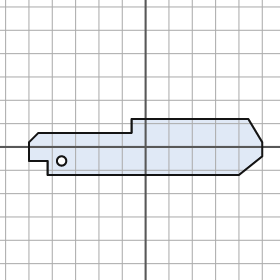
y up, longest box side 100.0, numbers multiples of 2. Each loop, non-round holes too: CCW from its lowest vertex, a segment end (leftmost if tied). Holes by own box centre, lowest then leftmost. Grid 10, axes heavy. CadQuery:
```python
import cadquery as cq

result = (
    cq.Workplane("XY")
    .moveTo(-42.0, -12.0)
    .lineTo(40.0, -12.0)
    .lineTo(50.0, -4.0)
    .lineTo(50.0, 2.0)
    .lineTo(44.0, 12.0)
    .lineTo(-6.0, 12.0)
    .lineTo(-6.0, 6.0)
    .lineTo(-46.0, 6.0)
    .lineTo(-50.0, 2.0)
    .lineTo(-50.0, -6.0)
    .lineTo(-42.0, -6.0)
    .close()
    .moveTo(-36.0, -6.0)
    .circle(2.0)
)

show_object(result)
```